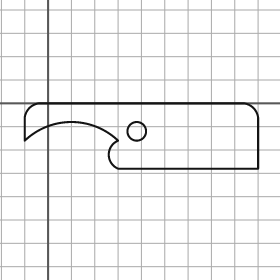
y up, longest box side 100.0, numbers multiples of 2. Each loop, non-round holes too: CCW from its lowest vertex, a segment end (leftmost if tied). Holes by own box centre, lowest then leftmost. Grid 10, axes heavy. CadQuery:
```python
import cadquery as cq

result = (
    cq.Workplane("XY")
    .moveTo(30.0, -28.0)
    .lineTo(90.0, -28.0)
    .lineTo(90.0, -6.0)
    .threePointArc((88.0, -2.0), (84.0, 0.0))
    .lineTo(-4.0, 0.0)
    .threePointArc((-8.0, -2.0), (-10.0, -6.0))
    .lineTo(-10.0, -16.0)
    .threePointArc((10.0, -8.0), (30.0, -16.0))
    .threePointArc((26.0, -22.0), (30.0, -28.0))
    .close()
    .moveTo(38.0, -12.0)
    .circle(4.0)
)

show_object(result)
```